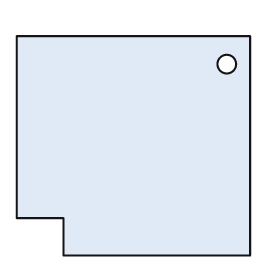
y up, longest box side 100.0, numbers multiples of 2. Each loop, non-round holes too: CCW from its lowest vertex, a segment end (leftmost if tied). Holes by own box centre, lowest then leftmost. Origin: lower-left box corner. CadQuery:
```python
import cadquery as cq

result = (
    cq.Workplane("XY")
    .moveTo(20.0, 0.0)
    .lineTo(100.0, 0.0)
    .lineTo(100.0, 94.0)
    .lineTo(0.0, 94.0)
    .lineTo(0.0, 16.0)
    .lineTo(20.0, 16.0)
    .close()
    .moveTo(90.0, 82.0)
    .circle(4.0)
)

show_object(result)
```